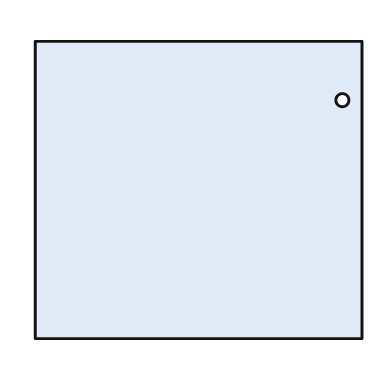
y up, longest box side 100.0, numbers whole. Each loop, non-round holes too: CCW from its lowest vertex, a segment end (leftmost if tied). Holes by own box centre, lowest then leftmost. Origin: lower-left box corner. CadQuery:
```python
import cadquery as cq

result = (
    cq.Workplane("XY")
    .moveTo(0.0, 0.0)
    .lineTo(100.0, 0.0)
    .lineTo(100.0, 91.0)
    .lineTo(0.0, 91.0)
    .close()
    .moveTo(94.0, 73.0)
    .circle(2.0)
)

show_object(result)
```